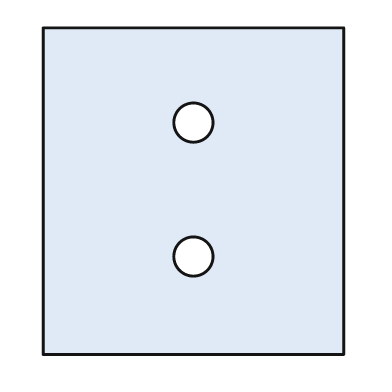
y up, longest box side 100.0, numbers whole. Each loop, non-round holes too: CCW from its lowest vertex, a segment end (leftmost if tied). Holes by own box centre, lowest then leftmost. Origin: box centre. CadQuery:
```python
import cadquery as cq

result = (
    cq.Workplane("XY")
    .moveTo(-46.0, -50.0)
    .lineTo(46.0, -50.0)
    .lineTo(46.0, 50.0)
    .lineTo(-46.0, 50.0)
    .close()
    .moveTo(0.0, -20.0)
    .circle(6.0)
    .moveTo(0.0, 21.0)
    .circle(6.0)
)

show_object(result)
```